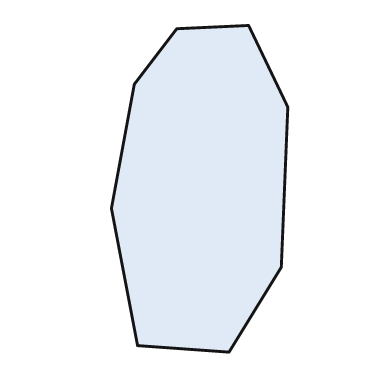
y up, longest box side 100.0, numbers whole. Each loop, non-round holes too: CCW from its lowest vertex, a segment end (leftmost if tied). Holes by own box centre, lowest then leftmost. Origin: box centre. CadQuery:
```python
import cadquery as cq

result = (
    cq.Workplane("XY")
    .moveTo(9.0, -50.0)
    .lineTo(25.0, -24.0)
    .lineTo(27.0, 25.0)
    .lineTo(15.0, 50.0)
    .lineTo(-7.0, 49.0)
    .lineTo(-20.0, 32.0)
    .lineTo(-27.0, -6.0)
    .lineTo(-19.0, -48.0)
    .close()
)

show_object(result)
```